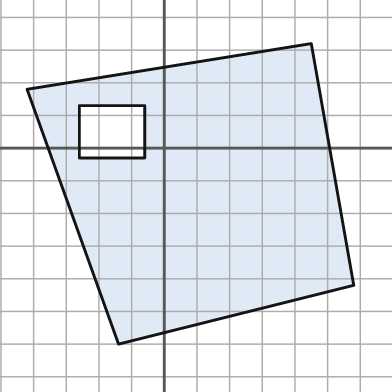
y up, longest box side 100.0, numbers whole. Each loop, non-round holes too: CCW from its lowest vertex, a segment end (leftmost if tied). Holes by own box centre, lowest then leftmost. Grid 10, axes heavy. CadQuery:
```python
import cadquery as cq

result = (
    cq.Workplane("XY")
    .moveTo(-14.0, -60.0)
    .lineTo(58.0, -42.0)
    .lineTo(45.0, 32.0)
    .lineTo(-42.0, 18.0)
    .close()
    .moveTo(-26.0, -3.0)
    .lineTo(-6.0, -3.0)
    .lineTo(-6.0, 13.0)
    .lineTo(-26.0, 13.0)
    .close()
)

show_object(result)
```